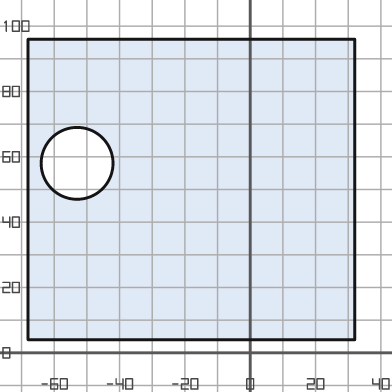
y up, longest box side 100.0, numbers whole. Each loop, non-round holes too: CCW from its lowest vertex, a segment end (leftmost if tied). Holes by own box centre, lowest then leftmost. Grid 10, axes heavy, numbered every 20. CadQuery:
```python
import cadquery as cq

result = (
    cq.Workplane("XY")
    .moveTo(-68.0, 4.0)
    .lineTo(32.0, 4.0)
    .lineTo(32.0, 96.0)
    .lineTo(-68.0, 96.0)
    .close()
    .moveTo(-53.0, 58.0)
    .circle(11.0)
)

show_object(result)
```